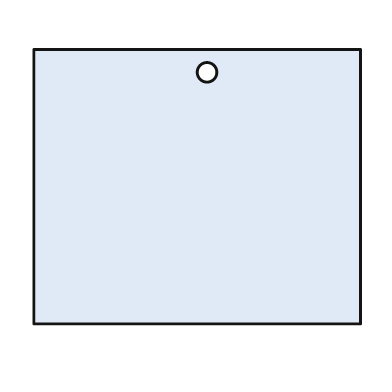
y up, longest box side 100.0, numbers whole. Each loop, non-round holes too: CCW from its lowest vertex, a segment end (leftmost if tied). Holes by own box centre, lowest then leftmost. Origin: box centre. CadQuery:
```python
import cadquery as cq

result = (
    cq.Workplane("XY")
    .moveTo(-50.0, -42.0)
    .lineTo(50.0, -42.0)
    .lineTo(50.0, 42.0)
    .lineTo(-50.0, 42.0)
    .close()
    .moveTo(3.0, 35.0)
    .circle(3.0)
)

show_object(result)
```